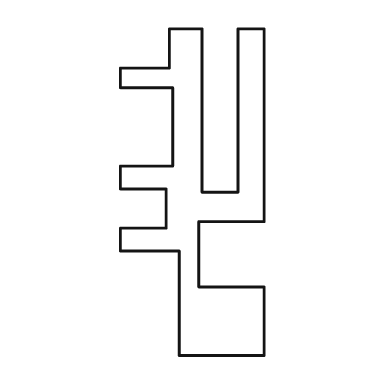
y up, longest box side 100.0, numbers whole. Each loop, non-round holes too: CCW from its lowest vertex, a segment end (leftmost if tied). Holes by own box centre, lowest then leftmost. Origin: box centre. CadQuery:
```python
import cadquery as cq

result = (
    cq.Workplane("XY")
    .moveTo(-4.0, -50.0)
    .lineTo(22.0, -50.0)
    .lineTo(22.0, -29.0)
    .lineTo(2.0, -29.0)
    .lineTo(2.0, -9.0)
    .lineTo(22.0, -9.0)
    .lineTo(22.0, 50.0)
    .lineTo(14.0, 50.0)
    .lineTo(14.0, 0.0)
    .lineTo(3.0, 0.0)
    .lineTo(3.0, 50.0)
    .lineTo(-7.0, 50.0)
    .lineTo(-7.0, 38.0)
    .lineTo(-22.0, 38.0)
    .lineTo(-22.0, 32.0)
    .lineTo(-6.0, 32.0)
    .lineTo(-6.0, 8.0)
    .lineTo(-22.0, 8.0)
    .lineTo(-22.0, 1.0)
    .lineTo(-8.0, 1.0)
    .lineTo(-8.0, -11.0)
    .lineTo(-22.0, -11.0)
    .lineTo(-22.0, -18.0)
    .lineTo(-4.0, -18.0)
    .close()
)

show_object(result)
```